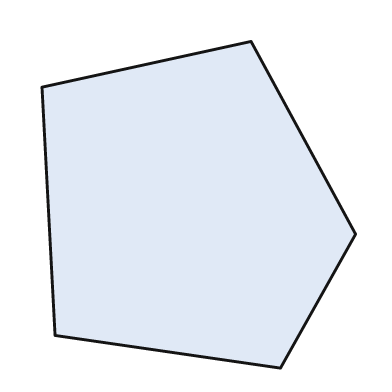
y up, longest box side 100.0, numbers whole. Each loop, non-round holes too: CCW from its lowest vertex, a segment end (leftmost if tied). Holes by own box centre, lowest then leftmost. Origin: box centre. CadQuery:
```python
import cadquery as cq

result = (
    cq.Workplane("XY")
    .moveTo(25.0, -50.0)
    .lineTo(48.0, -9.0)
    .lineTo(16.0, 50.0)
    .lineTo(-48.0, 36.0)
    .lineTo(-44.0, -40.0)
    .close()
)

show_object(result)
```